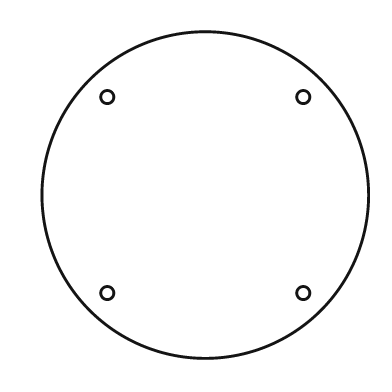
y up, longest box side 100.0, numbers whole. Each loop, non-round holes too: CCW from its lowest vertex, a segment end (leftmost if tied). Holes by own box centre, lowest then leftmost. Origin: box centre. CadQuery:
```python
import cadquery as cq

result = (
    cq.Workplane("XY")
    .moveTo(0.0, 0.0)
    .circle(50.0)
    .moveTo(-30.0, -30.0)
    .circle(2.0)
    .moveTo(30.0, -30.0)
    .circle(2.0)
    .moveTo(-30.0, 30.0)
    .circle(2.0)
    .moveTo(30.0, 30.0)
    .circle(2.0)
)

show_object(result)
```